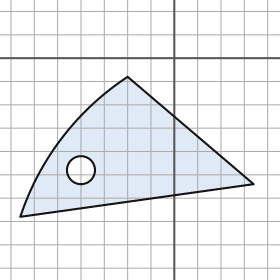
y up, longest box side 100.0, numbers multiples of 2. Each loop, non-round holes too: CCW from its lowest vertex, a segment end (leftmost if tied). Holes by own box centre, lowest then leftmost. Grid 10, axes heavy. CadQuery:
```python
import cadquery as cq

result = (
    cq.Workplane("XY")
    .moveTo(-66.0, -68.0)
    .lineTo(34.0, -54.0)
    .lineTo(-20.0, -8.0)
    .threePointArc((-48.0, -34.0), (-66.0, -68.0))
    .close()
    .moveTo(-40.0, -48.0)
    .circle(6.0)
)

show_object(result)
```